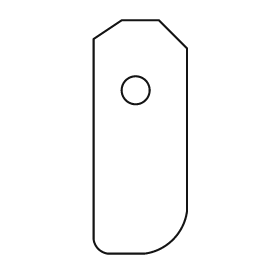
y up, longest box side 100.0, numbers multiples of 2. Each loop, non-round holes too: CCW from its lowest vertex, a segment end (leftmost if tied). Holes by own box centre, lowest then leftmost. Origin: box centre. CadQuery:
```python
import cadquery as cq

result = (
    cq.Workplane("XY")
    .moveTo(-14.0, -50.0)
    .lineTo(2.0, -50.0)
    .threePointArc((14.0, -44.0), (20.0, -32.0))
    .lineTo(20.0, 38.0)
    .lineTo(8.0, 50.0)
    .lineTo(-8.0, 50.0)
    .lineTo(-20.0, 42.0)
    .lineTo(-20.0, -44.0)
    .threePointArc((-18.0, -48.0), (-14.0, -50.0))
    .close()
    .moveTo(-2.0, 20.0)
    .circle(6.0)
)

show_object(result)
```